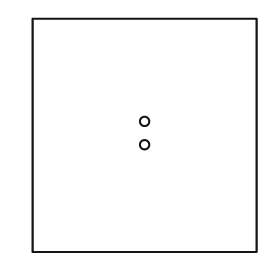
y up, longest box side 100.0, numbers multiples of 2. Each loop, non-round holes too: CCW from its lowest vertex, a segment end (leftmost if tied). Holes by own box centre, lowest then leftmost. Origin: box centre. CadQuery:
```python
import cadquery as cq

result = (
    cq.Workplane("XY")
    .moveTo(-48.0, -50.0)
    .lineTo(48.0, -50.0)
    .lineTo(48.0, 50.0)
    .lineTo(-48.0, 50.0)
    .close()
    .moveTo(0.0, -4.0)
    .circle(2.0)
    .moveTo(0.0, 6.0)
    .circle(2.0)
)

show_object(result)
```